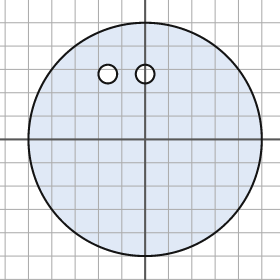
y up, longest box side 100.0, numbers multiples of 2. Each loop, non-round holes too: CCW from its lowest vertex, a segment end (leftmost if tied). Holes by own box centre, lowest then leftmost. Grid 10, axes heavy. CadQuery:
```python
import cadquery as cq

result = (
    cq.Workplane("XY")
    .moveTo(0.0, 0.0)
    .circle(50.0)
    .moveTo(-16.0, 28.0)
    .circle(4.0)
    .moveTo(0.0, 28.0)
    .circle(4.0)
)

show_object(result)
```